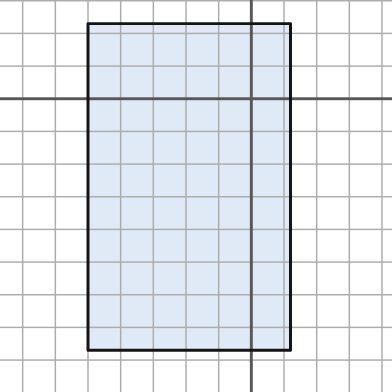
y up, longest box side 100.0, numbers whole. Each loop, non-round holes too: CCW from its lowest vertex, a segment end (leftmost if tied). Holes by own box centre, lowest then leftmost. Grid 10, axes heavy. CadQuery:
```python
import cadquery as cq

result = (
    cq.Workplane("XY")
    .moveTo(-50.0, -77.0)
    .lineTo(12.0, -77.0)
    .lineTo(12.0, 23.0)
    .lineTo(-50.0, 23.0)
    .close()
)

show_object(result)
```